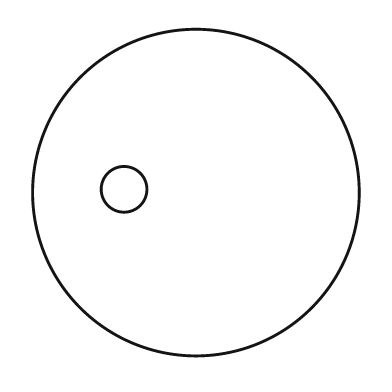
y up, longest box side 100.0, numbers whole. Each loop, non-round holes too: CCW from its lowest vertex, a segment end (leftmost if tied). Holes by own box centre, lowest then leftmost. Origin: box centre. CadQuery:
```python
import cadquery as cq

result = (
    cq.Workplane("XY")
    .moveTo(0.0, 0.0)
    .circle(50.0)
    .moveTo(-22.0, 1.0)
    .circle(7.0)
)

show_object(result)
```